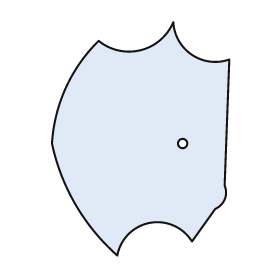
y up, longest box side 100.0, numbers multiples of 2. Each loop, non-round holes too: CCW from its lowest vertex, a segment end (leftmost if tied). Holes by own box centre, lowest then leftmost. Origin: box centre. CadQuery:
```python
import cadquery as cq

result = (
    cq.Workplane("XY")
    .moveTo(-10.0, -50.0)
    .threePointArc((4.0, -36.0), (22.0, -44.0))
    .lineTo(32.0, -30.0)
    .threePointArc((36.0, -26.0), (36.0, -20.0))
    .lineTo(38.0, 34.0)
    .threePointArc((22.0, 36.0), (14.0, 50.0))
    .threePointArc((0.0, 38.0), (-18.0, 42.0))
    .threePointArc((-32.0, 22.0), (-38.0, -2.0))
    .threePointArc((-28.0, -28.0), (-10.0, -50.0))
    .close()
    .moveTo(18.0, -2.0)
    .circle(2.0)
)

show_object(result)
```